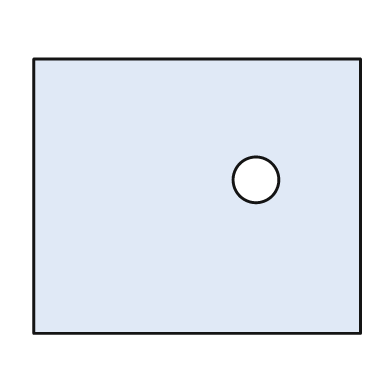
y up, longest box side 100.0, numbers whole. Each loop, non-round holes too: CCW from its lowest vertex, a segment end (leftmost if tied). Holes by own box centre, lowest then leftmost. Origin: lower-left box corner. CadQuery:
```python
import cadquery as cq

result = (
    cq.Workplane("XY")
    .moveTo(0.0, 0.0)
    .lineTo(100.0, 0.0)
    .lineTo(100.0, 84.0)
    .lineTo(0.0, 84.0)
    .close()
    .moveTo(68.0, 47.0)
    .circle(7.0)
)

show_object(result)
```